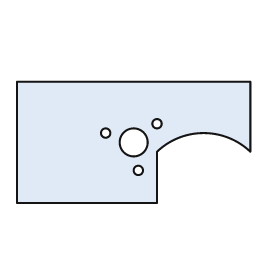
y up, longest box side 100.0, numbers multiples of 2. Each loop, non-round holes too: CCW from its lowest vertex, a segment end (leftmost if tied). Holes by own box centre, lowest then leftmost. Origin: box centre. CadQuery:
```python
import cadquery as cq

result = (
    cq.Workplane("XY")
    .moveTo(-50.0, -26.0)
    .lineTo(10.0, -26.0)
    .lineTo(10.0, -4.0)
    .threePointArc((30.0, 4.0), (50.0, -4.0))
    .lineTo(50.0, 26.0)
    .lineTo(-50.0, 26.0)
    .close()
    .moveTo(2.0, -12.0)
    .circle(2.0)
    .moveTo(0.0, 0.0)
    .circle(6.0)
    .moveTo(-12.0, 4.0)
    .circle(2.0)
    .moveTo(10.0, 8.0)
    .circle(2.0)
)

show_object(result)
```